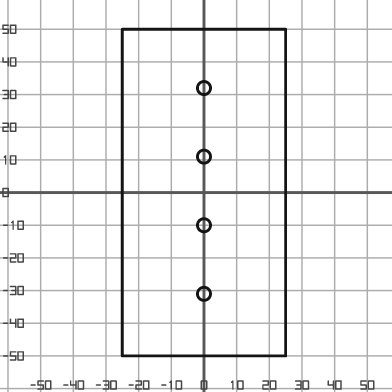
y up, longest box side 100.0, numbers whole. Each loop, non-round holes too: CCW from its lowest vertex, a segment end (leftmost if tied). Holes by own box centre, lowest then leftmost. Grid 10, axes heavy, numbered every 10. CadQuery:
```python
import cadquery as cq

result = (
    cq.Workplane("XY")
    .moveTo(-25.0, -50.0)
    .lineTo(25.0, -50.0)
    .lineTo(25.0, 50.0)
    .lineTo(-25.0, 50.0)
    .close()
    .moveTo(0.0, -31.0)
    .circle(2.0)
    .moveTo(0.0, -10.0)
    .circle(2.0)
    .moveTo(0.0, 11.0)
    .circle(2.0)
    .moveTo(0.0, 32.0)
    .circle(2.0)
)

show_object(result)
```